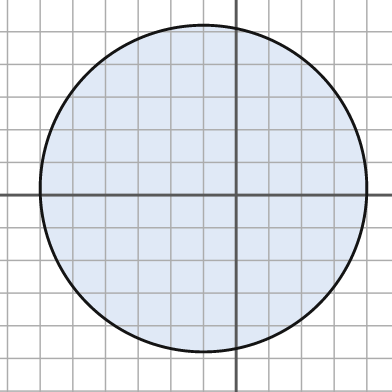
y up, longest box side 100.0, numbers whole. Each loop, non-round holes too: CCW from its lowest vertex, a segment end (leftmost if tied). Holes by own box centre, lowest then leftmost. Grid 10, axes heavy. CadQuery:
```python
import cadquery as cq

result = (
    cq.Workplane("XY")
    .moveTo(-10.0, 2.0)
    .circle(50.0)
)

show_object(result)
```